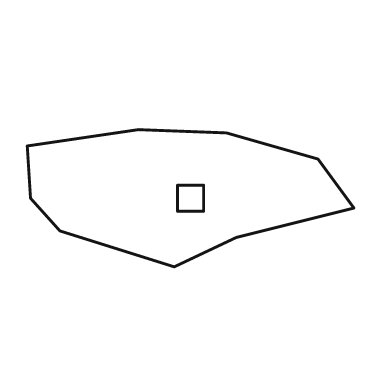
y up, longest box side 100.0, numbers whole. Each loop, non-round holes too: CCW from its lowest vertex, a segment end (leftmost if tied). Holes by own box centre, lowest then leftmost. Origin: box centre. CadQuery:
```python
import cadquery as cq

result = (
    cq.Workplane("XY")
    .moveTo(-5.0, -21.0)
    .lineTo(14.0, -12.0)
    .lineTo(50.0, -3.0)
    .lineTo(39.0, 12.0)
    .lineTo(11.0, 20.0)
    .lineTo(-16.0, 21.0)
    .lineTo(-50.0, 16.0)
    .lineTo(-49.0, 0.0)
    .lineTo(-40.0, -10.0)
    .close()
    .moveTo(-4.0, -4.0)
    .lineTo(4.0, -4.0)
    .lineTo(4.0, 4.0)
    .lineTo(-4.0, 4.0)
    .close()
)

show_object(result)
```